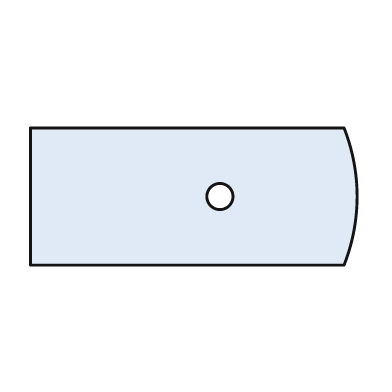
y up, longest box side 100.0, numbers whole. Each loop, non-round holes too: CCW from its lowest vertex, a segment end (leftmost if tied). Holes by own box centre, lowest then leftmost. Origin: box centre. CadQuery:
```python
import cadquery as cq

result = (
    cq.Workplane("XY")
    .moveTo(-50.0, -21.0)
    .lineTo(46.0, -21.0)
    .threePointArc((50.0, 0.0), (46.0, 21.0))
    .lineTo(-50.0, 21.0)
    .close()
    .moveTo(8.0, 0.0)
    .circle(4.0)
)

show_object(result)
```